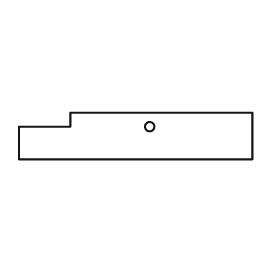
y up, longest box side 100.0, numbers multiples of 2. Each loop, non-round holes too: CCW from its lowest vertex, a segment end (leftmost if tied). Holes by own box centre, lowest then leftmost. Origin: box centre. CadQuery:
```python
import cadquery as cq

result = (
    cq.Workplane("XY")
    .moveTo(-50.0, -10.0)
    .lineTo(50.0, -10.0)
    .lineTo(50.0, 10.0)
    .lineTo(-28.0, 10.0)
    .lineTo(-28.0, 4.0)
    .lineTo(-50.0, 4.0)
    .close()
    .moveTo(6.0, 4.0)
    .circle(2.0)
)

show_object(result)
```